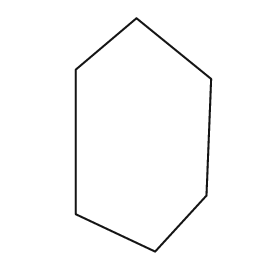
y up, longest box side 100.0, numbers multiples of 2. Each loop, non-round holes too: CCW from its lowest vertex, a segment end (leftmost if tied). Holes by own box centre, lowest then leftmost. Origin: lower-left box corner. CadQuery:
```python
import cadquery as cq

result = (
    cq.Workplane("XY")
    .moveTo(34.0, 0.0)
    .lineTo(56.0, 24.0)
    .lineTo(58.0, 74.0)
    .lineTo(26.0, 100.0)
    .lineTo(0.0, 78.0)
    .lineTo(0.0, 16.0)
    .close()
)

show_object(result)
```